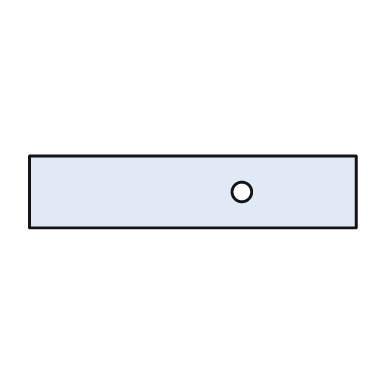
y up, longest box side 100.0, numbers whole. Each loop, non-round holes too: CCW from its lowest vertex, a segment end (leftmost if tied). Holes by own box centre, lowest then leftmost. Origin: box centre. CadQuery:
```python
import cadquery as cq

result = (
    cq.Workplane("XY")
    .moveTo(-50.0, -11.0)
    .lineTo(50.0, -11.0)
    .lineTo(50.0, 11.0)
    .lineTo(-50.0, 11.0)
    .close()
    .moveTo(15.0, 0.0)
    .circle(3.0)
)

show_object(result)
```